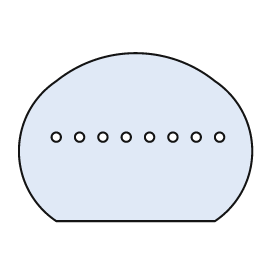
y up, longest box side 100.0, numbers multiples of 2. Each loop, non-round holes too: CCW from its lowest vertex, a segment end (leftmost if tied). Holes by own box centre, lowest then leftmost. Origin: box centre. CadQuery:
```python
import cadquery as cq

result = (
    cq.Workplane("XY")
    .moveTo(-34.0, -36.0)
    .lineTo(34.0, -36.0)
    .threePointArc((50.0, -6.0), (34.0, 24.0))
    .threePointArc((0.0, 36.0), (-34.0, 24.0))
    .threePointArc((-50.0, -6.0), (-34.0, -36.0))
    .close()
    .moveTo(-34.0, 0.0)
    .circle(2.0)
    .moveTo(-24.0, 0.0)
    .circle(2.0)
    .moveTo(-14.0, 0.0)
    .circle(2.0)
    .moveTo(-4.0, 0.0)
    .circle(2.0)
    .moveTo(6.0, 0.0)
    .circle(2.0)
    .moveTo(16.0, 0.0)
    .circle(2.0)
    .moveTo(26.0, 0.0)
    .circle(2.0)
    .moveTo(36.0, 0.0)
    .circle(2.0)
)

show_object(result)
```